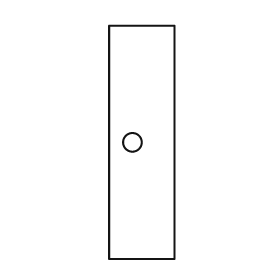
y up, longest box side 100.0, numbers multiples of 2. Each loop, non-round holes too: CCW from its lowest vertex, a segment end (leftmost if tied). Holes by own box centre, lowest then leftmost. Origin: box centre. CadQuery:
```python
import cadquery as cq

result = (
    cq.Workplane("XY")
    .moveTo(-14.0, -50.0)
    .lineTo(14.0, -50.0)
    .lineTo(14.0, 50.0)
    .lineTo(-14.0, 50.0)
    .close()
    .moveTo(-4.0, 0.0)
    .circle(4.0)
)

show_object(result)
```